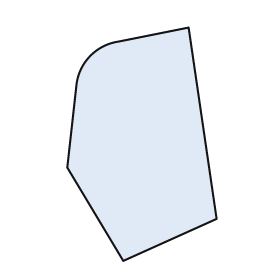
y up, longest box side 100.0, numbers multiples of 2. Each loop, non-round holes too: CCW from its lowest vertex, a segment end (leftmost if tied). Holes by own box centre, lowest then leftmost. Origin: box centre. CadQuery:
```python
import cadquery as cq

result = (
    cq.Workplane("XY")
    .moveTo(-8.0, -50.0)
    .lineTo(32.0, -32.0)
    .lineTo(20.0, 50.0)
    .lineTo(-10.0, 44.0)
    .threePointArc((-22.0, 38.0), (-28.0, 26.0))
    .lineTo(-32.0, -10.0)
    .close()
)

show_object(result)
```